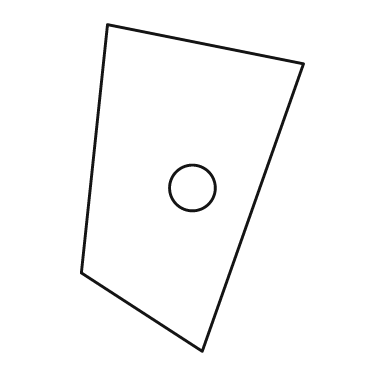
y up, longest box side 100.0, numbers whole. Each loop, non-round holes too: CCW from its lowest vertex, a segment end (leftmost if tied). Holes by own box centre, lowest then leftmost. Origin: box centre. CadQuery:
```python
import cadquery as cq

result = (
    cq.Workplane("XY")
    .moveTo(3.0, -50.0)
    .lineTo(34.0, 38.0)
    .lineTo(-26.0, 50.0)
    .lineTo(-34.0, -26.0)
    .close()
    .moveTo(0.0, 0.0)
    .circle(7.0)
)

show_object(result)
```